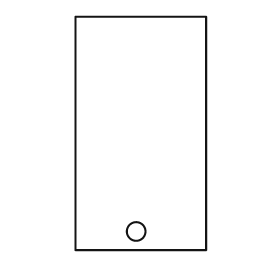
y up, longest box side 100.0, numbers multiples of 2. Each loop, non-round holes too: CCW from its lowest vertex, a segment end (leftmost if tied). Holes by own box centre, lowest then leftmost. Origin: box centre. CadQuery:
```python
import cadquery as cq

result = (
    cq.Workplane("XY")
    .moveTo(-28.0, -50.0)
    .lineTo(28.0, -50.0)
    .lineTo(28.0, 50.0)
    .lineTo(-28.0, 50.0)
    .close()
    .moveTo(-2.0, -42.0)
    .circle(4.0)
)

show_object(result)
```